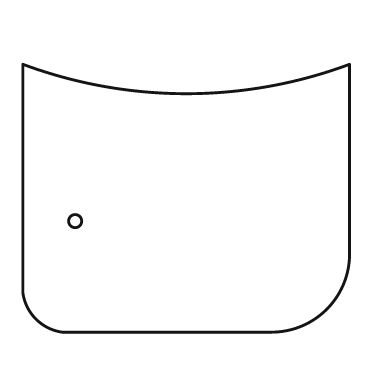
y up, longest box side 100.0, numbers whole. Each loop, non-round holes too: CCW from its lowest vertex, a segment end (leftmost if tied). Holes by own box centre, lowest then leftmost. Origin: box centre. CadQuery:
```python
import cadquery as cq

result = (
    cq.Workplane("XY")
    .moveTo(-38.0, -41.0)
    .lineTo(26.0, -41.0)
    .threePointArc((43.0, -34.0), (50.0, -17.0))
    .lineTo(50.0, 41.0)
    .threePointArc((0.0, 32.0), (-50.0, 41.0))
    .lineTo(-50.0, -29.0)
    .threePointArc((-46.0, -37.0), (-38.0, -41.0))
    .close()
    .moveTo(-34.0, -7.0)
    .circle(2.0)
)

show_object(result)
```